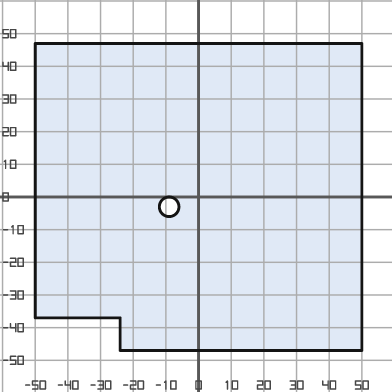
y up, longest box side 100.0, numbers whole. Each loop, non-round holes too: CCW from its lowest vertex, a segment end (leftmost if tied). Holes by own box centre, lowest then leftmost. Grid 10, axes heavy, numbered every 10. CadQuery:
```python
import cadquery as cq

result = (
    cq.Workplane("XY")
    .moveTo(-24.0, -47.0)
    .lineTo(50.0, -47.0)
    .lineTo(50.0, 47.0)
    .lineTo(-50.0, 47.0)
    .lineTo(-50.0, -37.0)
    .lineTo(-24.0, -37.0)
    .close()
    .moveTo(-9.0, -3.0)
    .circle(3.0)
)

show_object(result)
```